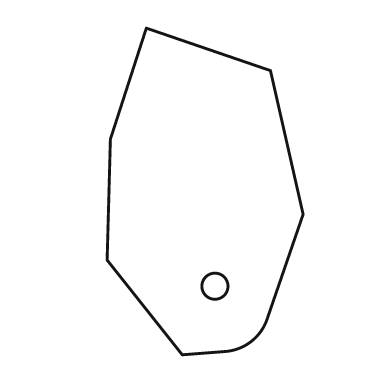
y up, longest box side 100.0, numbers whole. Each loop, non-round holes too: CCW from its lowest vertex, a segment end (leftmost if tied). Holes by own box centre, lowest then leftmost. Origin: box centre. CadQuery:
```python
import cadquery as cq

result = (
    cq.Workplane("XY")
    .moveTo(-7.0, -50.0)
    .lineTo(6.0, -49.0)
    .threePointArc((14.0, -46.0), (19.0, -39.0))
    .lineTo(30.0, -7.0)
    .lineTo(20.0, 37.0)
    .lineTo(-18.0, 50.0)
    .lineTo(-29.0, 16.0)
    .lineTo(-30.0, -21.0)
    .close()
    .moveTo(3.0, -29.0)
    .circle(4.0)
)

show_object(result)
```